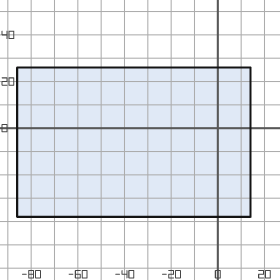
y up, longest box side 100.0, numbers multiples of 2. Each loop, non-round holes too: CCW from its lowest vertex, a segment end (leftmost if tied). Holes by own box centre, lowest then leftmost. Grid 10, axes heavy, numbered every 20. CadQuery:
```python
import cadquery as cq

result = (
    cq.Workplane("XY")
    .moveTo(-86.0, -38.0)
    .lineTo(14.0, -38.0)
    .lineTo(14.0, 26.0)
    .lineTo(-86.0, 26.0)
    .close()
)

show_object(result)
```